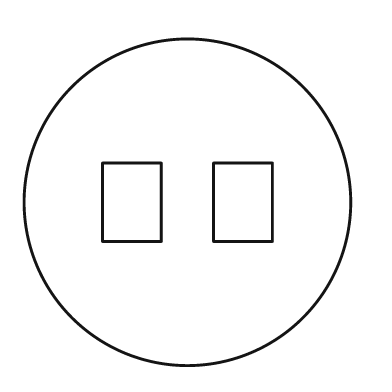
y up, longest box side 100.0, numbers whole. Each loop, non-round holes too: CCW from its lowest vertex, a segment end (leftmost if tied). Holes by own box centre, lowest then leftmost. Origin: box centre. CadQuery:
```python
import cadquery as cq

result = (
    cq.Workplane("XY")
    .moveTo(0.0, 0.0)
    .circle(50.0)
    .moveTo(-26.0, -12.0)
    .lineTo(-8.0, -12.0)
    .lineTo(-8.0, 12.0)
    .lineTo(-26.0, 12.0)
    .close()
    .moveTo(8.0, -12.0)
    .lineTo(26.0, -12.0)
    .lineTo(26.0, 12.0)
    .lineTo(8.0, 12.0)
    .close()
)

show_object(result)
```